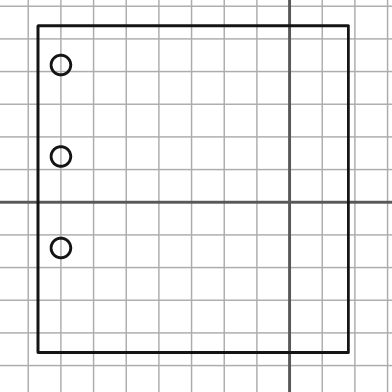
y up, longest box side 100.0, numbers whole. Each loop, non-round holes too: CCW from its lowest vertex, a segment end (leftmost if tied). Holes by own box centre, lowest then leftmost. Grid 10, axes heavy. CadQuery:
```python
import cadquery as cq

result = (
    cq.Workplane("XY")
    .moveTo(-77.0, -46.0)
    .lineTo(18.0, -46.0)
    .lineTo(18.0, 54.0)
    .lineTo(-77.0, 54.0)
    .close()
    .moveTo(-70.0, -14.0)
    .circle(3.0)
    .moveTo(-70.0, 14.0)
    .circle(3.0)
    .moveTo(-70.0, 42.0)
    .circle(3.0)
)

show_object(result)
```